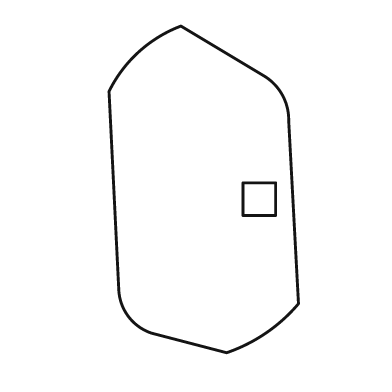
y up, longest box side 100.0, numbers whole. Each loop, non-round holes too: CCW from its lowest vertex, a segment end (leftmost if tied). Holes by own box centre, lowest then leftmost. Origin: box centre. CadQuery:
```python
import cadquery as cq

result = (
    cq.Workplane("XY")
    .moveTo(7.0, -50.0)
    .threePointArc((19.0, -44.0), (29.0, -35.0))
    .lineTo(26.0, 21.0)
    .threePointArc((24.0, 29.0), (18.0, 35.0))
    .lineTo(-7.0, 50.0)
    .threePointArc((-20.0, 42.0), (-29.0, 30.0))
    .lineTo(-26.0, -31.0)
    .threePointArc((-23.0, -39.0), (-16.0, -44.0))
    .close()
    .moveTo(12.0, -8.0)
    .lineTo(22.0, -8.0)
    .lineTo(22.0, 2.0)
    .lineTo(12.0, 2.0)
    .close()
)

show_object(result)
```